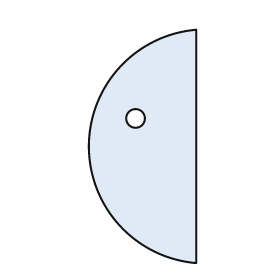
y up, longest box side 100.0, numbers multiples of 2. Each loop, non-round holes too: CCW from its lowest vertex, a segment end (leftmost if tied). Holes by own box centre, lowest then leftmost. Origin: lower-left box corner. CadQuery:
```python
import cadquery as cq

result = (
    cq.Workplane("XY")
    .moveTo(46.0, 0.0)
    .lineTo(46.0, 100.0)
    .threePointArc((0.0, 50.0), (46.0, 0.0))
    .close()
    .moveTo(20.0, 62.0)
    .circle(4.0)
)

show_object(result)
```